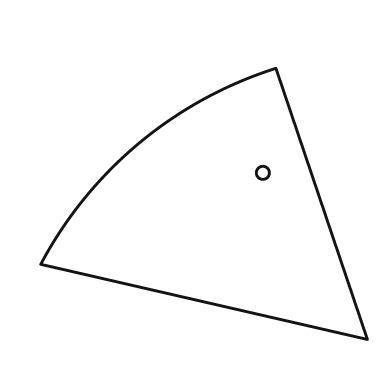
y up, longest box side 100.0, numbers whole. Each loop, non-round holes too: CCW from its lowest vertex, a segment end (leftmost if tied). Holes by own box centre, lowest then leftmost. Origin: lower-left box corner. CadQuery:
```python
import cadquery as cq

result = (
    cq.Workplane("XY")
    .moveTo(100.0, 0.0)
    .lineTo(72.0, 83.0)
    .threePointArc((30.0, 60.0), (0.0, 23.0))
    .close()
    .moveTo(68.0, 51.0)
    .circle(2.0)
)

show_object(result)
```